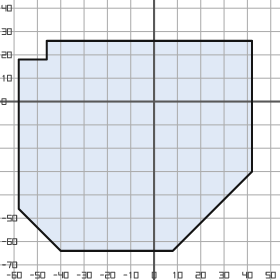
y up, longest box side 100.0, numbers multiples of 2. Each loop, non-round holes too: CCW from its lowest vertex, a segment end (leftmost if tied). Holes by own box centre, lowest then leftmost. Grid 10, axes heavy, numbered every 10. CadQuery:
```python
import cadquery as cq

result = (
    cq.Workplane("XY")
    .moveTo(-40.0, -64.0)
    .lineTo(8.0, -64.0)
    .lineTo(42.0, -30.0)
    .lineTo(42.0, 26.0)
    .lineTo(-46.0, 26.0)
    .lineTo(-46.0, 18.0)
    .lineTo(-58.0, 18.0)
    .lineTo(-58.0, -46.0)
    .close()
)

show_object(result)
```